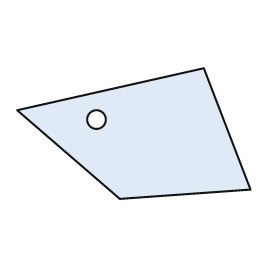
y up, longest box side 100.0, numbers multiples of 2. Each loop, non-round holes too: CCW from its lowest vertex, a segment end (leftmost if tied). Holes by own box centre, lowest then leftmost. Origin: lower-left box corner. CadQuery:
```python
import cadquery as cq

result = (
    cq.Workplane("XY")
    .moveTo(44.0, 0.0)
    .lineTo(100.0, 4.0)
    .lineTo(80.0, 56.0)
    .lineTo(0.0, 38.0)
    .close()
    .moveTo(34.0, 34.0)
    .circle(4.0)
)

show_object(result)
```